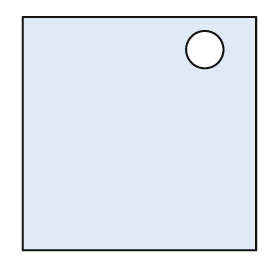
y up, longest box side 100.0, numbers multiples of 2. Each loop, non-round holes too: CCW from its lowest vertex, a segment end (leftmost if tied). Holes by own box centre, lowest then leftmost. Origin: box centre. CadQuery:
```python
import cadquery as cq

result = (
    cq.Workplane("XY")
    .moveTo(-50.0, -50.0)
    .lineTo(50.0, -50.0)
    .lineTo(50.0, 50.0)
    .lineTo(-50.0, 50.0)
    .close()
    .moveTo(28.0, 36.0)
    .circle(8.0)
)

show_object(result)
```